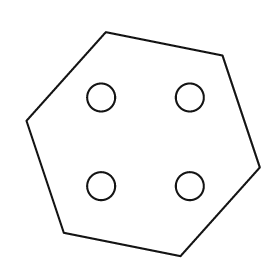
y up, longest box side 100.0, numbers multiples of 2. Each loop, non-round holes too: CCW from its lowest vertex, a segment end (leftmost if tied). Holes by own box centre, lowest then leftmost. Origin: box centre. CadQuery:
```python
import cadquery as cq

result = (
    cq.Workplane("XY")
    .moveTo(16.0, -48.0)
    .lineTo(50.0, -10.0)
    .lineTo(34.0, 38.0)
    .lineTo(-16.0, 48.0)
    .lineTo(-50.0, 10.0)
    .lineTo(-34.0, -38.0)
    .close()
    .moveTo(-18.0, -18.0)
    .circle(6.0)
    .moveTo(20.0, -18.0)
    .circle(6.0)
    .moveTo(-18.0, 20.0)
    .circle(6.0)
    .moveTo(20.0, 20.0)
    .circle(6.0)
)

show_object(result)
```